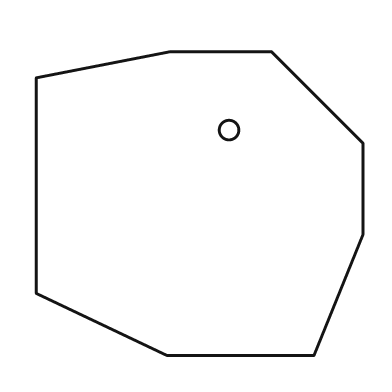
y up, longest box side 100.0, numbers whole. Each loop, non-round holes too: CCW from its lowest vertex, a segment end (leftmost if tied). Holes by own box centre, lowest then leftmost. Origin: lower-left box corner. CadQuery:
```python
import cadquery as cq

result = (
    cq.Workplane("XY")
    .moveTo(40.0, 0.0)
    .lineTo(85.0, 0.0)
    .lineTo(100.0, 37.0)
    .lineTo(100.0, 65.0)
    .lineTo(72.0, 93.0)
    .lineTo(41.0, 93.0)
    .lineTo(0.0, 85.0)
    .lineTo(0.0, 19.0)
    .close()
    .moveTo(59.0, 69.0)
    .circle(3.0)
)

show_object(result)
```